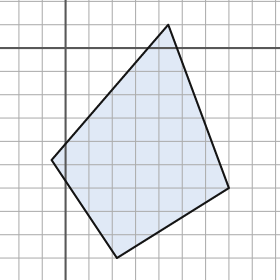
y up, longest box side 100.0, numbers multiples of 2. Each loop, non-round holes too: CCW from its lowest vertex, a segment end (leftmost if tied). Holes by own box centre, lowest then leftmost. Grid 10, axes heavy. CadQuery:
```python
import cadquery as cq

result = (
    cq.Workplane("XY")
    .moveTo(22.0, -90.0)
    .lineTo(70.0, -60.0)
    .lineTo(44.0, 10.0)
    .lineTo(-6.0, -48.0)
    .close()
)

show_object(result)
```